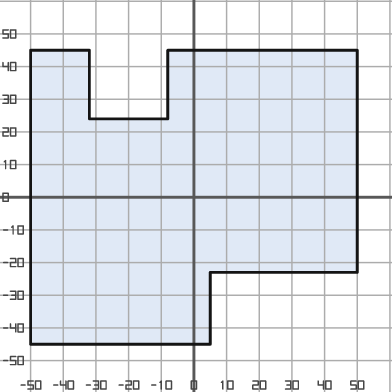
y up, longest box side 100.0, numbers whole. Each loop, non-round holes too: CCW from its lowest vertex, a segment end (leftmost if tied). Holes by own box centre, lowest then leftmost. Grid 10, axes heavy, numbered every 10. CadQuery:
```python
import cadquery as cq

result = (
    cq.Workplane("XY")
    .moveTo(-50.0, -45.0)
    .lineTo(5.0, -45.0)
    .lineTo(5.0, -23.0)
    .lineTo(50.0, -23.0)
    .lineTo(50.0, 45.0)
    .lineTo(-8.0, 45.0)
    .lineTo(-8.0, 24.0)
    .lineTo(-32.0, 24.0)
    .lineTo(-32.0, 45.0)
    .lineTo(-50.0, 45.0)
    .close()
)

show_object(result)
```